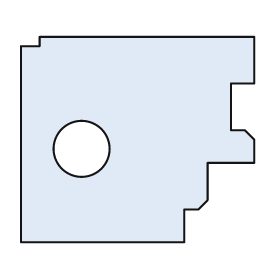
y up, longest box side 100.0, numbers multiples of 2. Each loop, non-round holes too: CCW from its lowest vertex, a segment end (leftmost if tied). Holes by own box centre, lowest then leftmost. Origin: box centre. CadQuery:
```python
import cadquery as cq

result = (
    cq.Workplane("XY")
    .moveTo(-50.0, -44.0)
    .lineTo(20.0, -44.0)
    .lineTo(20.0, -30.0)
    .lineTo(26.0, -30.0)
    .lineTo(30.0, -26.0)
    .lineTo(30.0, -10.0)
    .lineTo(50.0, -10.0)
    .lineTo(50.0, 0.0)
    .lineTo(46.0, 4.0)
    .lineTo(40.0, 4.0)
    .lineTo(40.0, 24.0)
    .lineTo(50.0, 24.0)
    .lineTo(50.0, 44.0)
    .lineTo(-42.0, 44.0)
    .lineTo(-42.0, 40.0)
    .lineTo(-50.0, 40.0)
    .close()
    .moveTo(-24.0, -4.0)
    .circle(12.0)
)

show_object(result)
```